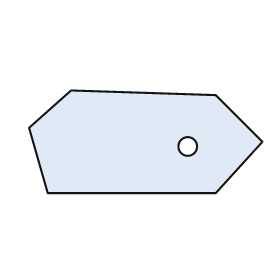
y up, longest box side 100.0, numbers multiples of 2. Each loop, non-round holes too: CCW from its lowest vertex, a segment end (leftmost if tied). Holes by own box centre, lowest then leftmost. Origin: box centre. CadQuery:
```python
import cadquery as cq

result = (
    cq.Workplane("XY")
    .moveTo(-42.0, -22.0)
    .lineTo(30.0, -22.0)
    .lineTo(50.0, 0.0)
    .lineTo(30.0, 20.0)
    .lineTo(-32.0, 22.0)
    .lineTo(-50.0, 6.0)
    .close()
    .moveTo(18.0, -2.0)
    .circle(4.0)
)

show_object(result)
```